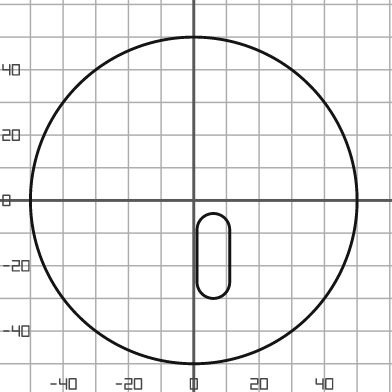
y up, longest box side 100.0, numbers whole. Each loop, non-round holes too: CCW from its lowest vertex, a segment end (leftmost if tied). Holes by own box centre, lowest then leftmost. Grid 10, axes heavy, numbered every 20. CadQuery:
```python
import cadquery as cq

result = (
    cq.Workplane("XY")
    .moveTo(0.0, 0.0)
    .circle(50.0)
    .moveTo(1.0, -25.0)
    .threePointArc((6.0, -30.0), (11.0, -25.0))
    .lineTo(11.0, -9.0)
    .threePointArc((6.0, -4.0), (1.0, -9.0))
    .close()
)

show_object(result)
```